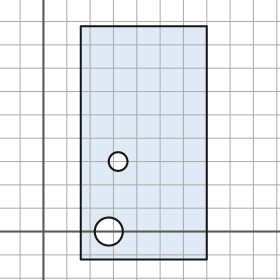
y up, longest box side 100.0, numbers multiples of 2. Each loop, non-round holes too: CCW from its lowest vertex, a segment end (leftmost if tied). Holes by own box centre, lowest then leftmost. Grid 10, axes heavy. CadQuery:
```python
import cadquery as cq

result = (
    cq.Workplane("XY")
    .moveTo(16.0, -12.0)
    .lineTo(70.0, -12.0)
    .lineTo(70.0, 88.0)
    .lineTo(16.0, 88.0)
    .close()
    .moveTo(28.0, 0.0)
    .circle(6.0)
    .moveTo(32.0, 30.0)
    .circle(4.0)
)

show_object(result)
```